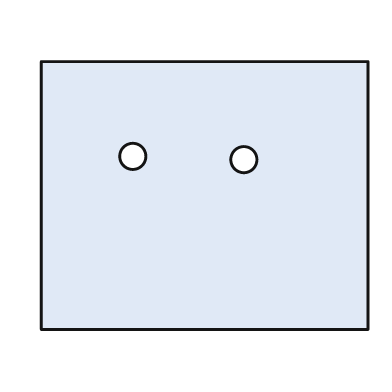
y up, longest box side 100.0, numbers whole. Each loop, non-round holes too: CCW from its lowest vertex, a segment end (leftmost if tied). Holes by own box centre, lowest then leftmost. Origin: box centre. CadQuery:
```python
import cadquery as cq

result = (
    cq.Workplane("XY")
    .moveTo(-50.0, -41.0)
    .lineTo(50.0, -41.0)
    .lineTo(50.0, 41.0)
    .lineTo(-50.0, 41.0)
    .close()
    .moveTo(12.0, 11.0)
    .circle(4.0)
    .moveTo(-22.0, 12.0)
    .circle(4.0)
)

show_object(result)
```